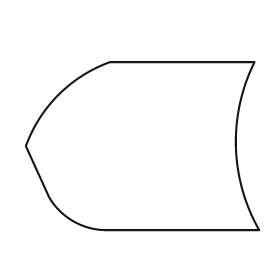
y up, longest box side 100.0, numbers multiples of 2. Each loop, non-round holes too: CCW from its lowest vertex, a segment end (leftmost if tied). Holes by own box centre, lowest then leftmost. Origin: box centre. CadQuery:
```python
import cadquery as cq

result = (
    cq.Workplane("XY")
    .moveTo(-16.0, -36.0)
    .lineTo(50.0, -36.0)
    .threePointArc((40.0, 0.0), (48.0, 36.0))
    .lineTo(-14.0, 36.0)
    .threePointArc((-36.0, 22.0), (-50.0, 0.0))
    .lineTo(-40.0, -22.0)
    .threePointArc((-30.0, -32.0), (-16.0, -36.0))
    .close()
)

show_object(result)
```